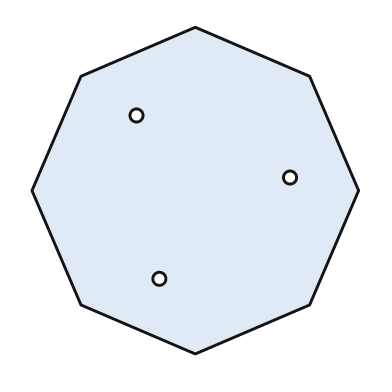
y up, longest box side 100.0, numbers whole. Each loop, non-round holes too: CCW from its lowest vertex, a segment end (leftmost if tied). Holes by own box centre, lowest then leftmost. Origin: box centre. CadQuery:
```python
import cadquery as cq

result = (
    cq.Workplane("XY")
    .moveTo(0.0, -50.0)
    .lineTo(35.0, -35.0)
    .lineTo(50.0, 0.0)
    .lineTo(35.0, 35.0)
    .lineTo(0.0, 50.0)
    .lineTo(-35.0, 35.0)
    .lineTo(-50.0, 0.0)
    .lineTo(-35.0, -35.0)
    .close()
    .moveTo(-11.0, -27.0)
    .circle(2.0)
    .moveTo(29.0, 4.0)
    .circle(2.0)
    .moveTo(-18.0, 23.0)
    .circle(2.0)
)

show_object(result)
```